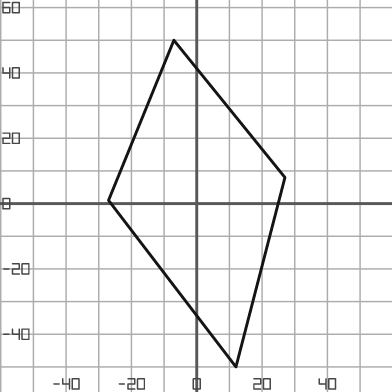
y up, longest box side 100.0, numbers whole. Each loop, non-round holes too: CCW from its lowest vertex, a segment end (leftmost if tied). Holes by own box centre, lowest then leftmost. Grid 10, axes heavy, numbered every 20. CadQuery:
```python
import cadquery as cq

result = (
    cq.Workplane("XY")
    .moveTo(12.0, -50.0)
    .lineTo(27.0, 8.0)
    .lineTo(-7.0, 50.0)
    .lineTo(-27.0, 1.0)
    .close()
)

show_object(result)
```